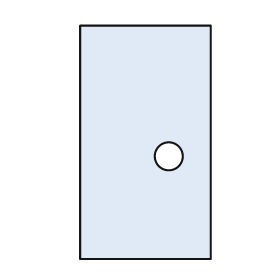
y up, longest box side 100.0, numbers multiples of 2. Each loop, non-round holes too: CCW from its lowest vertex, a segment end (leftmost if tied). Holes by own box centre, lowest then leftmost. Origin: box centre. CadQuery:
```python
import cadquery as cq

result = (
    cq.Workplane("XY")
    .moveTo(-28.0, -50.0)
    .lineTo(28.0, -50.0)
    .lineTo(28.0, 50.0)
    .lineTo(-28.0, 50.0)
    .close()
    .moveTo(10.0, -6.0)
    .circle(6.0)
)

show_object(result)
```